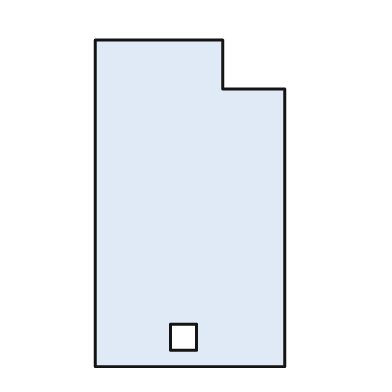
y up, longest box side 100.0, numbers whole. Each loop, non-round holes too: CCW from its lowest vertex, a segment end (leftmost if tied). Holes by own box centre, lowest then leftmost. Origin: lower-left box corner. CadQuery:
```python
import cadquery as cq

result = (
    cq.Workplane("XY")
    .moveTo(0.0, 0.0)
    .lineTo(58.0, 0.0)
    .lineTo(58.0, 85.0)
    .lineTo(39.0, 85.0)
    .lineTo(39.0, 100.0)
    .lineTo(0.0, 100.0)
    .close()
    .moveTo(23.0, 5.0)
    .lineTo(31.0, 5.0)
    .lineTo(31.0, 13.0)
    .lineTo(23.0, 13.0)
    .close()
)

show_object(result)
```